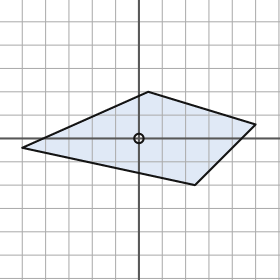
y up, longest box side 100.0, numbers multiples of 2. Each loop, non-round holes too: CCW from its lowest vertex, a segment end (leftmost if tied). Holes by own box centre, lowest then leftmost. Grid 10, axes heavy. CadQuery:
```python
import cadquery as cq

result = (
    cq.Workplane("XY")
    .moveTo(24.0, -20.0)
    .lineTo(50.0, 6.0)
    .lineTo(4.0, 20.0)
    .lineTo(-50.0, -4.0)
    .close()
    .moveTo(0.0, 0.0)
    .circle(2.0)
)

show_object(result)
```